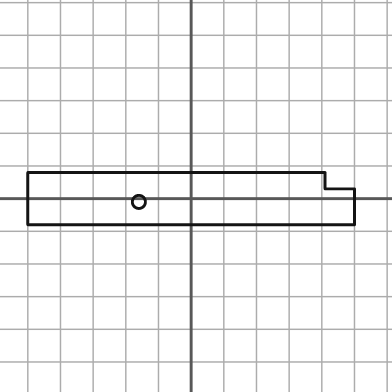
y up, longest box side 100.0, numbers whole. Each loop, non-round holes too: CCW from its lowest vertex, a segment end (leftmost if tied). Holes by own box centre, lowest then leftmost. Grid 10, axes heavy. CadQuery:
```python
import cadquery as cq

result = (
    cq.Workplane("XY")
    .moveTo(-50.0, -8.0)
    .lineTo(50.0, -8.0)
    .lineTo(50.0, 3.0)
    .lineTo(41.0, 3.0)
    .lineTo(41.0, 8.0)
    .lineTo(-50.0, 8.0)
    .close()
    .moveTo(-16.0, -1.0)
    .circle(2.0)
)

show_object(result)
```